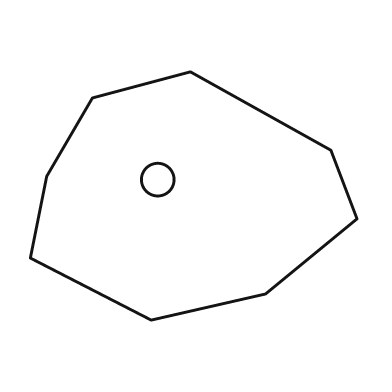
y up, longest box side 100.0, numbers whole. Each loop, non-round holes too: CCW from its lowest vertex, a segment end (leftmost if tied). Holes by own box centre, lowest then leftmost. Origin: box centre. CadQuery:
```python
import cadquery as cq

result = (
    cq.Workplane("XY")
    .moveTo(-13.0, -38.0)
    .lineTo(22.0, -30.0)
    .lineTo(50.0, -7.0)
    .lineTo(42.0, 14.0)
    .lineTo(-1.0, 38.0)
    .lineTo(-31.0, 30.0)
    .lineTo(-45.0, 6.0)
    .lineTo(-50.0, -19.0)
    .close()
    .moveTo(-11.0, 5.0)
    .circle(5.0)
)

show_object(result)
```